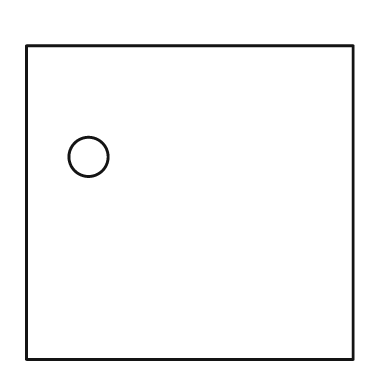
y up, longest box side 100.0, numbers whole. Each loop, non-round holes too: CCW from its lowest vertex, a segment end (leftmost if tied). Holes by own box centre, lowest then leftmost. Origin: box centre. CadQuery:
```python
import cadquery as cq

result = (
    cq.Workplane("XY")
    .moveTo(-50.0, -48.0)
    .lineTo(50.0, -48.0)
    .lineTo(50.0, 48.0)
    .lineTo(-50.0, 48.0)
    .close()
    .moveTo(-31.0, 14.0)
    .circle(6.0)
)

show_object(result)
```